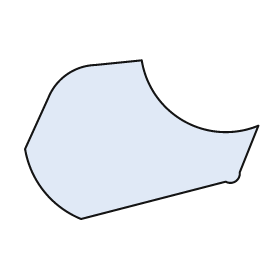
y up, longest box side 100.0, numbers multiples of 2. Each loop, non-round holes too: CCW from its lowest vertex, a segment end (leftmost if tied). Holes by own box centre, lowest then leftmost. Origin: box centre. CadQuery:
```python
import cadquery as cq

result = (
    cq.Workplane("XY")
    .moveTo(-26.0, -34.0)
    .lineTo(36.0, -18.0)
    .threePointArc((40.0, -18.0), (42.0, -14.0))
    .lineTo(50.0, 6.0)
    .threePointArc((18.0, 8.0), (0.0, 34.0))
    .lineTo(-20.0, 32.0)
    .threePointArc((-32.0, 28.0), (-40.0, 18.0))
    .lineTo(-50.0, -4.0)
    .threePointArc((-42.0, -22.0), (-26.0, -34.0))
    .close()
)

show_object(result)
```